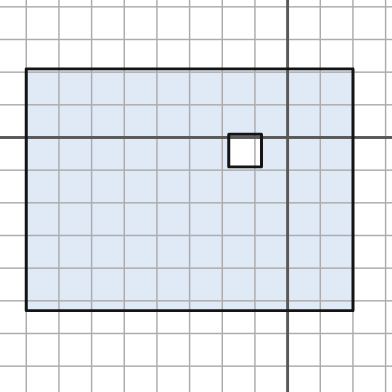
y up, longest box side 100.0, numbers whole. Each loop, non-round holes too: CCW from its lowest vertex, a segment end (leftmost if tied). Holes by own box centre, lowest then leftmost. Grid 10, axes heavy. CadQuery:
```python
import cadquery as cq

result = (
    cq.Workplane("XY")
    .moveTo(-80.0, -53.0)
    .lineTo(20.0, -53.0)
    .lineTo(20.0, 21.0)
    .lineTo(-80.0, 21.0)
    .close()
    .moveTo(-18.0, -9.0)
    .lineTo(-8.0, -9.0)
    .lineTo(-8.0, 1.0)
    .lineTo(-18.0, 1.0)
    .close()
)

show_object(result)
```